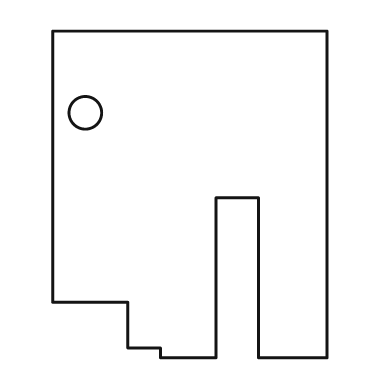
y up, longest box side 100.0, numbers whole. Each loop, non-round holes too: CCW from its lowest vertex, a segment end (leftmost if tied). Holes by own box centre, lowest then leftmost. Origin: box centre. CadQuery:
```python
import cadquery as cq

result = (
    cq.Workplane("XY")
    .moveTo(-9.0, -50.0)
    .lineTo(8.0, -50.0)
    .lineTo(8.0, -1.0)
    .lineTo(21.0, -1.0)
    .lineTo(21.0, -50.0)
    .lineTo(42.0, -50.0)
    .lineTo(42.0, 50.0)
    .lineTo(-42.0, 50.0)
    .lineTo(-42.0, -33.0)
    .lineTo(-19.0, -33.0)
    .lineTo(-19.0, -47.0)
    .lineTo(-9.0, -47.0)
    .close()
    .moveTo(-32.0, 25.0)
    .circle(5.0)
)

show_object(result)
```